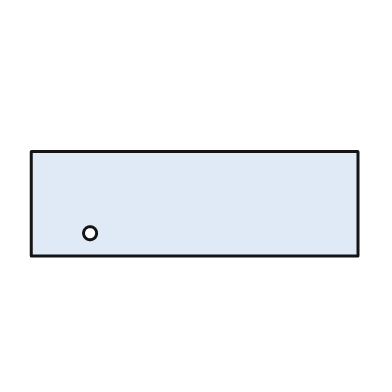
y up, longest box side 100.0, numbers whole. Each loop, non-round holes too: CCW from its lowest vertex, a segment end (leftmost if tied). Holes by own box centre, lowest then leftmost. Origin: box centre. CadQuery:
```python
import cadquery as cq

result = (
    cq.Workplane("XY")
    .moveTo(-50.0, -16.0)
    .lineTo(50.0, -16.0)
    .lineTo(50.0, 16.0)
    .lineTo(-50.0, 16.0)
    .close()
    .moveTo(-32.0, -9.0)
    .circle(2.0)
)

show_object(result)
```